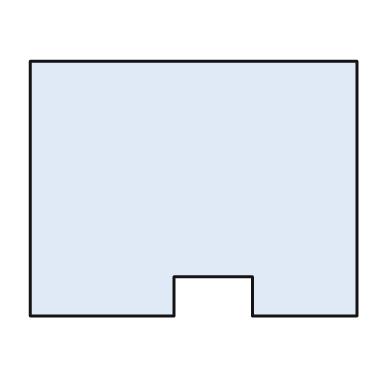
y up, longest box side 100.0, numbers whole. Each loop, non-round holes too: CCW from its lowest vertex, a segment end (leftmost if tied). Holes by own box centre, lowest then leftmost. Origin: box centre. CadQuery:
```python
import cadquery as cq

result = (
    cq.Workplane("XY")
    .moveTo(-50.0, -39.0)
    .lineTo(-6.0, -39.0)
    .lineTo(-6.0, -27.0)
    .lineTo(18.0, -27.0)
    .lineTo(18.0, -39.0)
    .lineTo(50.0, -39.0)
    .lineTo(50.0, 39.0)
    .lineTo(-50.0, 39.0)
    .close()
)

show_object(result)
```